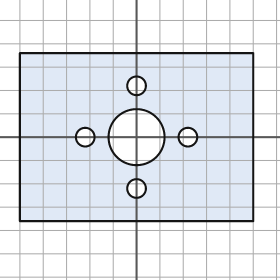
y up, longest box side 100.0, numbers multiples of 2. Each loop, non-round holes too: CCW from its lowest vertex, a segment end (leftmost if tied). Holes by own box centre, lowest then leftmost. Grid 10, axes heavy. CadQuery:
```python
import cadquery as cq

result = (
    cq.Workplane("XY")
    .moveTo(-50.0, -36.0)
    .lineTo(50.0, -36.0)
    .lineTo(50.0, 36.0)
    .lineTo(-50.0, 36.0)
    .close()
    .moveTo(0.0, -22.0)
    .circle(4.0)
    .moveTo(-22.0, 0.0)
    .circle(4.0)
    .moveTo(0.0, 0.0)
    .circle(12.0)
    .moveTo(22.0, 0.0)
    .circle(4.0)
    .moveTo(0.0, 22.0)
    .circle(4.0)
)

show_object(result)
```